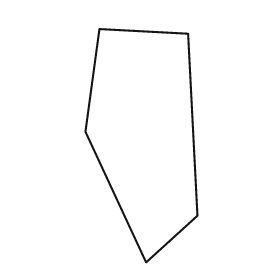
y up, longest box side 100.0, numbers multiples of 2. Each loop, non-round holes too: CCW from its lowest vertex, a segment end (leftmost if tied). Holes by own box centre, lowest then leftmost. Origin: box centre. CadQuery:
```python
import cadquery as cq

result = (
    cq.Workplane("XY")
    .moveTo(2.0, -50.0)
    .lineTo(24.0, -30.0)
    .lineTo(20.0, 48.0)
    .lineTo(-18.0, 50.0)
    .lineTo(-24.0, 6.0)
    .close()
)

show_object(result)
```